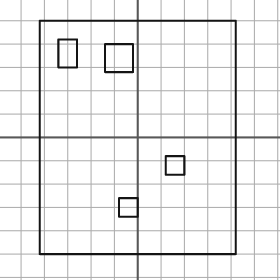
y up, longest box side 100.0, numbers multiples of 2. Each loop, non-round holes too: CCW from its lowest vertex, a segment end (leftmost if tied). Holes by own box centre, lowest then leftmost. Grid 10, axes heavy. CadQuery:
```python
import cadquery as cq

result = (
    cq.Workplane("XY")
    .moveTo(-42.0, -50.0)
    .lineTo(42.0, -50.0)
    .lineTo(42.0, 50.0)
    .lineTo(-42.0, 50.0)
    .close()
    .moveTo(-8.0, -34.0)
    .lineTo(0.0, -34.0)
    .lineTo(0.0, -26.0)
    .lineTo(-8.0, -26.0)
    .close()
    .moveTo(12.0, -16.0)
    .lineTo(20.0, -16.0)
    .lineTo(20.0, -8.0)
    .lineTo(12.0, -8.0)
    .close()
    .moveTo(-14.0, 28.0)
    .lineTo(-2.0, 28.0)
    .lineTo(-2.0, 40.0)
    .lineTo(-14.0, 40.0)
    .close()
    .moveTo(-34.0, 30.0)
    .lineTo(-26.0, 30.0)
    .lineTo(-26.0, 42.0)
    .lineTo(-34.0, 42.0)
    .close()
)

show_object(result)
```